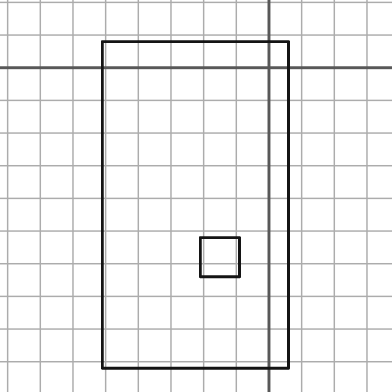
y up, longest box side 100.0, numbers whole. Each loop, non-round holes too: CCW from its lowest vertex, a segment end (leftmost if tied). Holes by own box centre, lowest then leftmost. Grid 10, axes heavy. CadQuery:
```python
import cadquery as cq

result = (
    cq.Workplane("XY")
    .moveTo(-51.0, -92.0)
    .lineTo(6.0, -92.0)
    .lineTo(6.0, 8.0)
    .lineTo(-51.0, 8.0)
    .close()
    .moveTo(-21.0, -64.0)
    .lineTo(-9.0, -64.0)
    .lineTo(-9.0, -52.0)
    .lineTo(-21.0, -52.0)
    .close()
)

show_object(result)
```